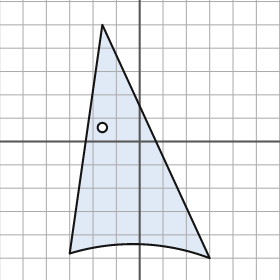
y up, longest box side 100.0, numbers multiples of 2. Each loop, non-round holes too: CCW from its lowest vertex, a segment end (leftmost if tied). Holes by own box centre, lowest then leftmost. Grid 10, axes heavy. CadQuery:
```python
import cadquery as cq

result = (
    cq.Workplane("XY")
    .moveTo(30.0, -50.0)
    .lineTo(-16.0, 50.0)
    .lineTo(-30.0, -48.0)
    .threePointArc((0.0, -44.0), (30.0, -50.0))
    .close()
    .moveTo(-16.0, 6.0)
    .circle(2.0)
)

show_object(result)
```